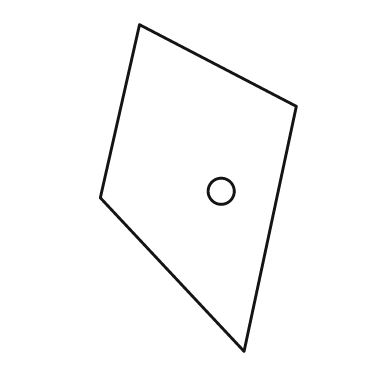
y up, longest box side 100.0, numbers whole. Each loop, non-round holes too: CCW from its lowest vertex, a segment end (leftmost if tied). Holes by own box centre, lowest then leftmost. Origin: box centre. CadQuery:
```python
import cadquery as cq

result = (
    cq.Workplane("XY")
    .moveTo(14.0, -50.0)
    .lineTo(30.0, 25.0)
    .lineTo(-18.0, 50.0)
    .lineTo(-30.0, -3.0)
    .close()
    .moveTo(7.0, -1.0)
    .circle(4.0)
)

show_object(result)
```